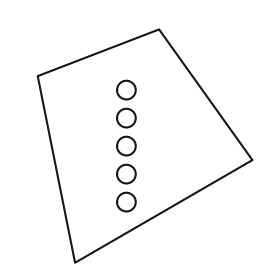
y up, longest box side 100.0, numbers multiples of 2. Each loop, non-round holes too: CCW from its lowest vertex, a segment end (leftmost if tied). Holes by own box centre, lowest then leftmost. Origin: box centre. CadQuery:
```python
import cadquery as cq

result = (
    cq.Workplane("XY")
    .moveTo(-30.0, -50.0)
    .lineTo(46.0, -6.0)
    .lineTo(6.0, 50.0)
    .lineTo(-46.0, 30.0)
    .close()
    .moveTo(-8.0, -24.0)
    .circle(4.0)
    .moveTo(-8.0, -12.0)
    .circle(4.0)
    .moveTo(-8.0, 0.0)
    .circle(4.0)
    .moveTo(-8.0, 12.0)
    .circle(4.0)
    .moveTo(-8.0, 24.0)
    .circle(4.0)
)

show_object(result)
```